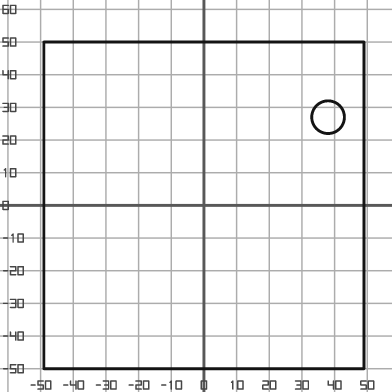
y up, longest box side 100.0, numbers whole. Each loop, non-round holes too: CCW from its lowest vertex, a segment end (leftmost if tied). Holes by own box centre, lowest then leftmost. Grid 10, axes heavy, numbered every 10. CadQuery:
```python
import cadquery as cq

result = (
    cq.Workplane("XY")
    .moveTo(-49.0, -50.0)
    .lineTo(49.0, -50.0)
    .lineTo(49.0, 50.0)
    .lineTo(-49.0, 50.0)
    .close()
    .moveTo(38.0, 27.0)
    .circle(5.0)
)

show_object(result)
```